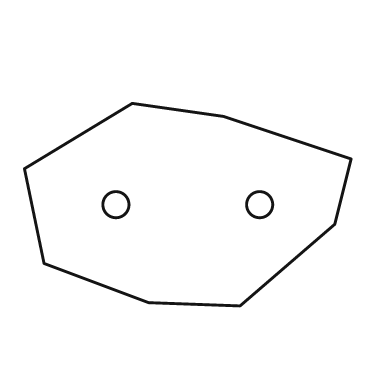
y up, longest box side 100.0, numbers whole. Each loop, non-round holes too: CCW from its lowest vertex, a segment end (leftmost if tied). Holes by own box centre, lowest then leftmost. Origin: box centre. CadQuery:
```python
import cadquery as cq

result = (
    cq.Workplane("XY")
    .moveTo(16.0, -31.0)
    .lineTo(45.0, -6.0)
    .lineTo(50.0, 14.0)
    .lineTo(11.0, 27.0)
    .lineTo(-17.0, 31.0)
    .lineTo(-50.0, 11.0)
    .lineTo(-44.0, -18.0)
    .lineTo(-12.0, -30.0)
    .close()
    .moveTo(-22.0, 0.0)
    .circle(4.0)
    .moveTo(22.0, 0.0)
    .circle(4.0)
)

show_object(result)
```